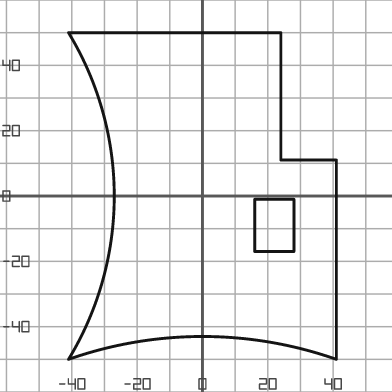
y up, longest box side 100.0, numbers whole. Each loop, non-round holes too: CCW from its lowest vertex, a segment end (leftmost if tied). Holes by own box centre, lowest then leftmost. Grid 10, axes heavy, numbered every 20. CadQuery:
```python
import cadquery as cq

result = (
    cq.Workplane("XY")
    .moveTo(-41.0, -50.0)
    .threePointArc((0.0, -43.0), (41.0, -50.0))
    .lineTo(41.0, 11.0)
    .lineTo(24.0, 11.0)
    .lineTo(24.0, 50.0)
    .lineTo(-41.0, 50.0)
    .threePointArc((-27.0, 0.0), (-41.0, -50.0))
    .close()
    .moveTo(16.0, -17.0)
    .lineTo(28.0, -17.0)
    .lineTo(28.0, -1.0)
    .lineTo(16.0, -1.0)
    .close()
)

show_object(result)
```